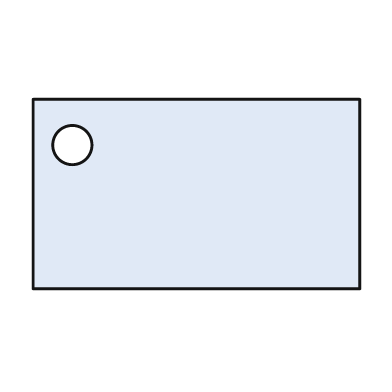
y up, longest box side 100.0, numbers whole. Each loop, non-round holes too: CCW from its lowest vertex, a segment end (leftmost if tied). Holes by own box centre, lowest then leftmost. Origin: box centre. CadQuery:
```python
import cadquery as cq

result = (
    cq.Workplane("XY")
    .moveTo(-50.0, -29.0)
    .lineTo(50.0, -29.0)
    .lineTo(50.0, 29.0)
    .lineTo(-50.0, 29.0)
    .close()
    .moveTo(-38.0, 15.0)
    .circle(6.0)
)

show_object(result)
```